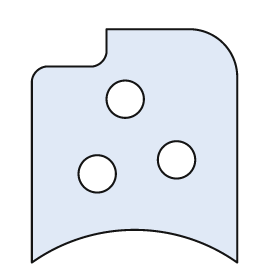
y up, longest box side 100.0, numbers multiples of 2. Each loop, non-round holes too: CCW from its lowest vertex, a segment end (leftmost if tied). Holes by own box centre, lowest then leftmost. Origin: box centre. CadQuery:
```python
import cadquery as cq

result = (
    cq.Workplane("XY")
    .moveTo(-44.0, -50.0)
    .threePointArc((0.0, -36.0), (44.0, -50.0))
    .lineTo(44.0, 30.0)
    .threePointArc((38.0, 44.0), (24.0, 50.0))
    .lineTo(-12.0, 50.0)
    .lineTo(-12.0, 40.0)
    .threePointArc((-14.0, 36.0), (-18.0, 34.0))
    .lineTo(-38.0, 34.0)
    .threePointArc((-42.0, 32.0), (-44.0, 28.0))
    .close()
    .moveTo(-16.0, -12.0)
    .circle(8.0)
    .moveTo(18.0, -6.0)
    .circle(8.0)
    .moveTo(-4.0, 20.0)
    .circle(8.0)
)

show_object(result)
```